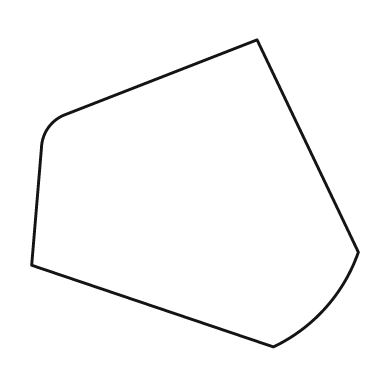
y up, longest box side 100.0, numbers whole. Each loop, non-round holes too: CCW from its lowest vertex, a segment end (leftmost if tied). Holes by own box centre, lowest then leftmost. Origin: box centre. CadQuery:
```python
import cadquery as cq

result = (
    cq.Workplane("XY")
    .moveTo(24.0, -47.0)
    .threePointArc((40.0, -35.0), (50.0, -18.0))
    .lineTo(19.0, 47.0)
    .lineTo(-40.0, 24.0)
    .threePointArc((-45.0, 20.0), (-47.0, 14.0))
    .lineTo(-50.0, -22.0)
    .close()
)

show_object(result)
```